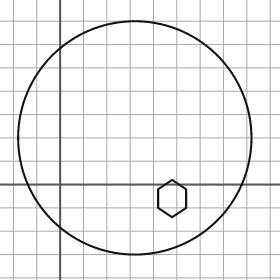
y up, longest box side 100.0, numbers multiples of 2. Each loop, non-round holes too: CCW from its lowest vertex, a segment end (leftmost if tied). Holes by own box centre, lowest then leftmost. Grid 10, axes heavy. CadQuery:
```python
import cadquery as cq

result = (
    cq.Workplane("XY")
    .moveTo(32.0, 20.0)
    .circle(50.0)
    .moveTo(48.0, -14.0)
    .lineTo(54.0, -10.0)
    .lineTo(54.0, -2.0)
    .lineTo(48.0, 2.0)
    .lineTo(42.0, -2.0)
    .lineTo(42.0, -10.0)
    .close()
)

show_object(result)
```